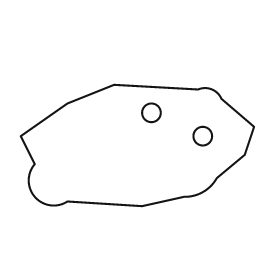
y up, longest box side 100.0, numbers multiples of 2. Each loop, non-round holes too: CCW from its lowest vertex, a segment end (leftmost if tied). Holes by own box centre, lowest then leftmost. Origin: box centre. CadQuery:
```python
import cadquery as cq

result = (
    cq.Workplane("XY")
    .moveTo(2.0, -26.0)
    .lineTo(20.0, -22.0)
    .threePointArc((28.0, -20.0), (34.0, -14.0))
    .lineTo(46.0, -4.0)
    .lineTo(50.0, 8.0)
    .lineTo(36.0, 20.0)
    .threePointArc((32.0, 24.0), (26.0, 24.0))
    .lineTo(-10.0, 26.0)
    .lineTo(-30.0, 18.0)
    .lineTo(-50.0, 4.0)
    .lineTo(-44.0, -8.0)
    .threePointArc((-44.0, -22.0), (-30.0, -24.0))
    .close()
    .moveTo(28.0, 4.0)
    .circle(4.0)
    .moveTo(6.0, 14.0)
    .circle(4.0)
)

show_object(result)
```